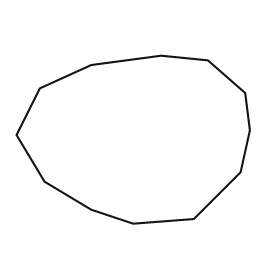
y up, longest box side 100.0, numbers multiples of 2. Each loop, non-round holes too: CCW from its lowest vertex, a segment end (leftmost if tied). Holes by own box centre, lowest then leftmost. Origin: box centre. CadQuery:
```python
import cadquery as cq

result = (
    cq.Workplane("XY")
    .moveTo(0.0, -36.0)
    .lineTo(26.0, -34.0)
    .lineTo(46.0, -14.0)
    .lineTo(50.0, 4.0)
    .lineTo(48.0, 20.0)
    .lineTo(32.0, 34.0)
    .lineTo(12.0, 36.0)
    .lineTo(-18.0, 32.0)
    .lineTo(-40.0, 22.0)
    .lineTo(-50.0, 2.0)
    .lineTo(-38.0, -18.0)
    .lineTo(-18.0, -30.0)
    .close()
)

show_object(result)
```